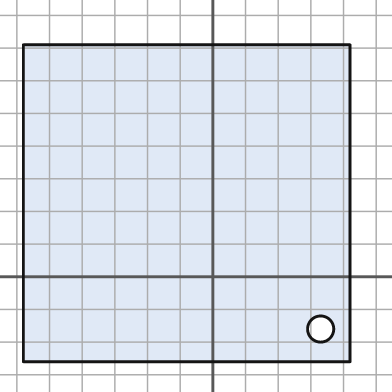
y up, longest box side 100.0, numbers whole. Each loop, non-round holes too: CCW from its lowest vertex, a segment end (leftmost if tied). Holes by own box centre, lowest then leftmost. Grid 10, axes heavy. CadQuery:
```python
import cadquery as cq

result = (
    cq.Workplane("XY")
    .moveTo(-58.0, -26.0)
    .lineTo(42.0, -26.0)
    .lineTo(42.0, 71.0)
    .lineTo(-58.0, 71.0)
    .close()
    .moveTo(33.0, -16.0)
    .circle(4.0)
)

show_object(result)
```